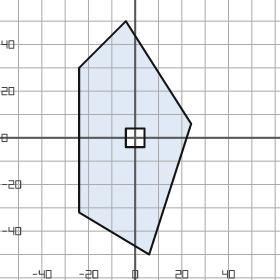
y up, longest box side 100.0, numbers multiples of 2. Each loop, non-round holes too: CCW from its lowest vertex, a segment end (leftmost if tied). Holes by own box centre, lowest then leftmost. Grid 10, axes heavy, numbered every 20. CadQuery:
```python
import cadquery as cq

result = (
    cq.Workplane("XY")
    .moveTo(6.0, -50.0)
    .lineTo(24.0, 6.0)
    .lineTo(-4.0, 50.0)
    .lineTo(-24.0, 30.0)
    .lineTo(-24.0, -32.0)
    .close()
    .moveTo(-4.0, -4.0)
    .lineTo(4.0, -4.0)
    .lineTo(4.0, 4.0)
    .lineTo(-4.0, 4.0)
    .close()
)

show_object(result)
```